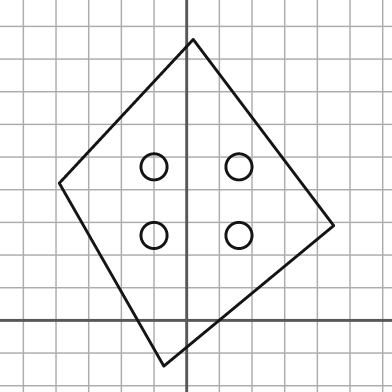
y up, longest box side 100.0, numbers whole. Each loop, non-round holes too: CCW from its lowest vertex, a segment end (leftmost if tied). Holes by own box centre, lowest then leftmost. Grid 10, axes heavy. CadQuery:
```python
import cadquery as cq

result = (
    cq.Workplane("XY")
    .moveTo(-7.0, -14.0)
    .lineTo(45.0, 29.0)
    .lineTo(2.0, 86.0)
    .lineTo(-39.0, 42.0)
    .close()
    .moveTo(-10.0, 26.0)
    .circle(4.0)
    .moveTo(16.0, 26.0)
    .circle(4.0)
    .moveTo(-10.0, 47.0)
    .circle(4.0)
    .moveTo(16.0, 47.0)
    .circle(4.0)
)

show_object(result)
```